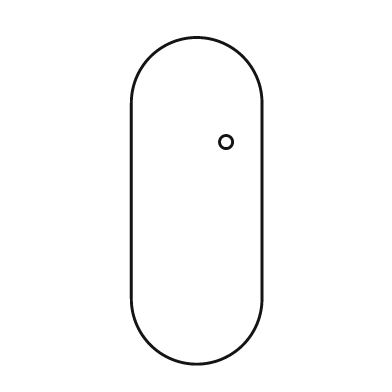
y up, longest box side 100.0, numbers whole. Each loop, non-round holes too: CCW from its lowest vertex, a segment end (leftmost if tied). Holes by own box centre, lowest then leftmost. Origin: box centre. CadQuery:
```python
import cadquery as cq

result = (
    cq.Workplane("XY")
    .moveTo(-20.0, -30.0)
    .threePointArc((0.0, -50.0), (20.0, -30.0))
    .lineTo(20.0, 30.0)
    .threePointArc((0.0, 50.0), (-20.0, 30.0))
    .close()
    .moveTo(9.0, 18.0)
    .circle(2.0)
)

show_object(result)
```